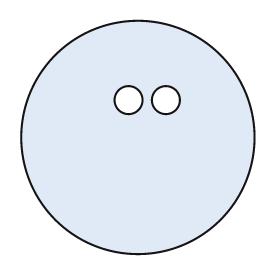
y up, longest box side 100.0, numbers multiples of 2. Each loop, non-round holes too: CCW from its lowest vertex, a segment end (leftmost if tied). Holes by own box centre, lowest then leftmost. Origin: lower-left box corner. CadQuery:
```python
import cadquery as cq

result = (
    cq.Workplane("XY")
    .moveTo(50.0, 50.0)
    .circle(50.0)
    .moveTo(46.0, 66.0)
    .circle(6.0)
    .moveTo(62.0, 66.0)
    .circle(6.0)
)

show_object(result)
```